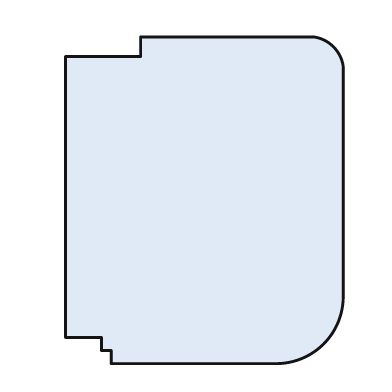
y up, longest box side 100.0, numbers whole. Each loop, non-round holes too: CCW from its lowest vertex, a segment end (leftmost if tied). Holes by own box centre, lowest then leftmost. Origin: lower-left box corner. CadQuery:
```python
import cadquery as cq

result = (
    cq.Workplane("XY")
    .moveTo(14.0, 0.0)
    .lineTo(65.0, 0.0)
    .threePointArc((79.0, 6.0), (85.0, 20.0))
    .lineTo(85.0, 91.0)
    .threePointArc((82.0, 97.0), (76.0, 100.0))
    .lineTo(23.0, 100.0)
    .lineTo(23.0, 94.0)
    .lineTo(0.0, 94.0)
    .lineTo(0.0, 8.0)
    .lineTo(11.0, 8.0)
    .lineTo(11.0, 4.0)
    .lineTo(14.0, 4.0)
    .close()
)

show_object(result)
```